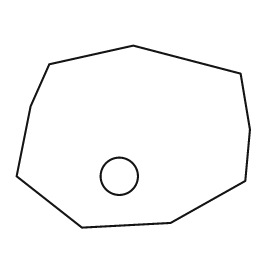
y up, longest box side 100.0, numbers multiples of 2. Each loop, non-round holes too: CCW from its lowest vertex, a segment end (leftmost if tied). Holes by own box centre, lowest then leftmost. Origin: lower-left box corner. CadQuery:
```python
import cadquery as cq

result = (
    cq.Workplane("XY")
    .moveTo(28.0, 0.0)
    .lineTo(66.0, 2.0)
    .lineTo(98.0, 20.0)
    .lineTo(100.0, 42.0)
    .lineTo(96.0, 66.0)
    .lineTo(50.0, 78.0)
    .lineTo(14.0, 70.0)
    .lineTo(6.0, 52.0)
    .lineTo(0.0, 22.0)
    .close()
    .moveTo(44.0, 22.0)
    .circle(8.0)
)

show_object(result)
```